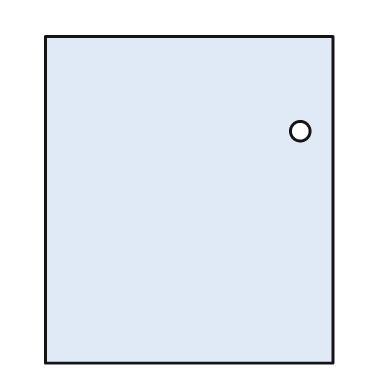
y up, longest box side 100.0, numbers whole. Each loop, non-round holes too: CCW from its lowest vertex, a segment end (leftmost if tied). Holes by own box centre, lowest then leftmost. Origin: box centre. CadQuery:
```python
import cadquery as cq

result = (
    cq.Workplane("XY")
    .moveTo(-44.0, -50.0)
    .lineTo(44.0, -50.0)
    .lineTo(44.0, 50.0)
    .lineTo(-44.0, 50.0)
    .close()
    .moveTo(34.0, 21.0)
    .circle(3.0)
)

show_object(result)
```